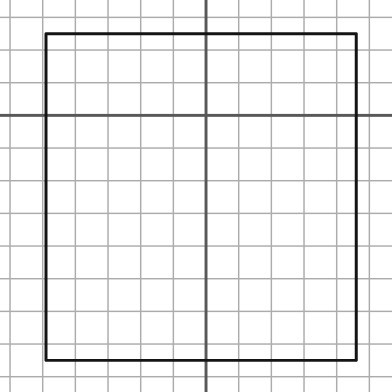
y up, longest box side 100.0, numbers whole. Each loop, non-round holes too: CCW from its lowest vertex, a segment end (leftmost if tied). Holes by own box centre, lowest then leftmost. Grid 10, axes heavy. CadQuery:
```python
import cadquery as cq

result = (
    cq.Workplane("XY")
    .moveTo(-49.0, -75.0)
    .lineTo(46.0, -75.0)
    .lineTo(46.0, 25.0)
    .lineTo(-49.0, 25.0)
    .close()
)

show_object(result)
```